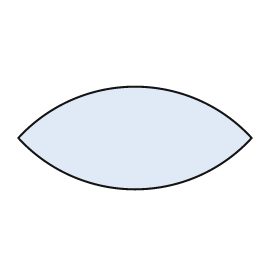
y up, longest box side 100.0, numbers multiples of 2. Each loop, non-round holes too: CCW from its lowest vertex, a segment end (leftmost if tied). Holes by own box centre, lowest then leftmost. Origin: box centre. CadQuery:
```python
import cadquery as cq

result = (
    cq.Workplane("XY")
    .moveTo(-50.0, 0.0)
    .threePointArc((0.0, -22.0), (50.0, 0.0))
    .threePointArc((0.0, 22.0), (-50.0, 0.0))
    .close()
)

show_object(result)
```